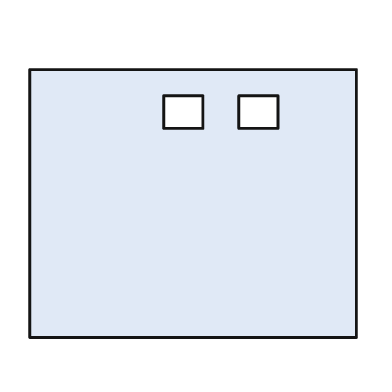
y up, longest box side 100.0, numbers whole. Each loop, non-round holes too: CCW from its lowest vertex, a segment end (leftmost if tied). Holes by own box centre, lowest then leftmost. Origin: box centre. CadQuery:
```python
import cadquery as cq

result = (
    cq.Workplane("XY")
    .moveTo(-50.0, -41.0)
    .lineTo(50.0, -41.0)
    .lineTo(50.0, 41.0)
    .lineTo(-50.0, 41.0)
    .close()
    .moveTo(-9.0, 23.0)
    .lineTo(3.0, 23.0)
    .lineTo(3.0, 33.0)
    .lineTo(-9.0, 33.0)
    .close()
    .moveTo(14.0, 23.0)
    .lineTo(26.0, 23.0)
    .lineTo(26.0, 33.0)
    .lineTo(14.0, 33.0)
    .close()
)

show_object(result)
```